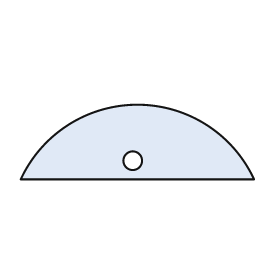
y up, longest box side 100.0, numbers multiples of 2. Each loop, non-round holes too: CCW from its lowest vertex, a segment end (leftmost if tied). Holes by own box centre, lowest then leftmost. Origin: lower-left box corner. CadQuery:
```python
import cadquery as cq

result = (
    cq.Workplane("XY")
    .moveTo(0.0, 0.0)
    .lineTo(100.0, 0.0)
    .threePointArc((50.0, 32.0), (0.0, 0.0))
    .close()
    .moveTo(48.0, 8.0)
    .circle(4.0)
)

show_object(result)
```